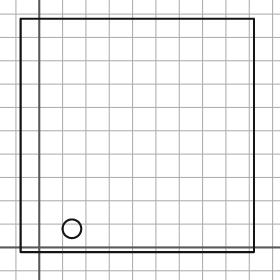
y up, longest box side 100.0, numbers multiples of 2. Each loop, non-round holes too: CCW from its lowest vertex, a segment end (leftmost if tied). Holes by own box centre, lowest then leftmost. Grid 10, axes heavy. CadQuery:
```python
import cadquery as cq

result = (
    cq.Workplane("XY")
    .moveTo(-8.0, -2.0)
    .lineTo(92.0, -2.0)
    .lineTo(92.0, 98.0)
    .lineTo(-8.0, 98.0)
    .close()
    .moveTo(14.0, 8.0)
    .circle(4.0)
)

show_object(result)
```